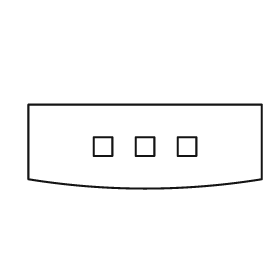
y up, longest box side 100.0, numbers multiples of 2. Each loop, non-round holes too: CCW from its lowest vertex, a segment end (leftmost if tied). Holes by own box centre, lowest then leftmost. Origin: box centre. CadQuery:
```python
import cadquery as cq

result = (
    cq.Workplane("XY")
    .moveTo(-50.0, -14.0)
    .threePointArc((0.0, -18.0), (50.0, -14.0))
    .lineTo(50.0, 18.0)
    .lineTo(-50.0, 18.0)
    .close()
    .moveTo(-22.0, -4.0)
    .lineTo(-14.0, -4.0)
    .lineTo(-14.0, 4.0)
    .lineTo(-22.0, 4.0)
    .close()
    .moveTo(-4.0, -4.0)
    .lineTo(4.0, -4.0)
    .lineTo(4.0, 4.0)
    .lineTo(-4.0, 4.0)
    .close()
    .moveTo(14.0, -4.0)
    .lineTo(22.0, -4.0)
    .lineTo(22.0, 4.0)
    .lineTo(14.0, 4.0)
    .close()
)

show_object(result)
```